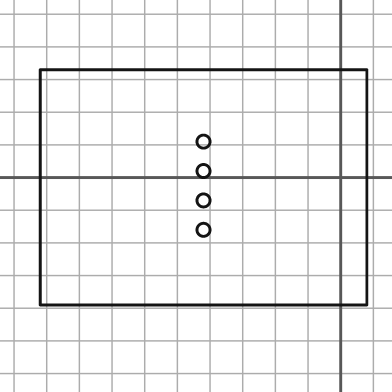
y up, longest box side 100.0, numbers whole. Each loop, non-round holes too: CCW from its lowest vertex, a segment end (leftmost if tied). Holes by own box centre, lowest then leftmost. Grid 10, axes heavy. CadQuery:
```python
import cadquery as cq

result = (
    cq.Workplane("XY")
    .moveTo(-92.0, -39.0)
    .lineTo(8.0, -39.0)
    .lineTo(8.0, 33.0)
    .lineTo(-92.0, 33.0)
    .close()
    .moveTo(-42.0, -16.0)
    .circle(2.0)
    .moveTo(-42.0, -7.0)
    .circle(2.0)
    .moveTo(-42.0, 2.0)
    .circle(2.0)
    .moveTo(-42.0, 11.0)
    .circle(2.0)
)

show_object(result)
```